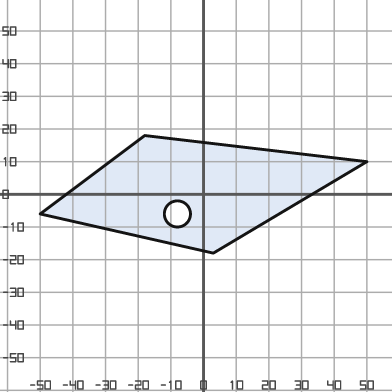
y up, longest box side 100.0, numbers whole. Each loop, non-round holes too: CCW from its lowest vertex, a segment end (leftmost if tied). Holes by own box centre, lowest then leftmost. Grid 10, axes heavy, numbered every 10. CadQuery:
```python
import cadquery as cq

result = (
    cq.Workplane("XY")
    .moveTo(3.0, -18.0)
    .lineTo(50.0, 10.0)
    .lineTo(-18.0, 18.0)
    .lineTo(-50.0, -6.0)
    .close()
    .moveTo(-8.0, -6.0)
    .circle(4.0)
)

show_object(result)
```